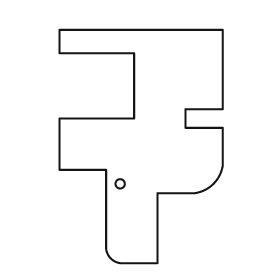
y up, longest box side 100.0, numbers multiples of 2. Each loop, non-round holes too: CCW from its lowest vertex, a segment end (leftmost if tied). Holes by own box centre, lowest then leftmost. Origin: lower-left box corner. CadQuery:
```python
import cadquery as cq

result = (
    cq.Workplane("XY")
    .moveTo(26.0, 0.0)
    .lineTo(42.0, 0.0)
    .lineTo(42.0, 30.0)
    .lineTo(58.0, 30.0)
    .threePointArc((66.0, 34.0), (70.0, 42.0))
    .lineTo(70.0, 58.0)
    .lineTo(54.0, 58.0)
    .lineTo(54.0, 66.0)
    .lineTo(70.0, 66.0)
    .lineTo(70.0, 100.0)
    .lineTo(0.0, 100.0)
    .lineTo(0.0, 90.0)
    .lineTo(32.0, 90.0)
    .lineTo(32.0, 62.0)
    .lineTo(0.0, 62.0)
    .lineTo(0.0, 40.0)
    .lineTo(20.0, 40.0)
    .lineTo(20.0, 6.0)
    .threePointArc((22.0, 2.0), (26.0, 0.0))
    .close()
    .moveTo(26.0, 34.0)
    .circle(2.0)
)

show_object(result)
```